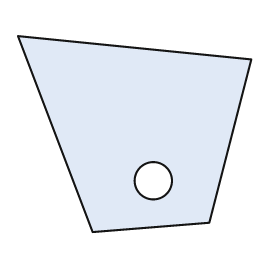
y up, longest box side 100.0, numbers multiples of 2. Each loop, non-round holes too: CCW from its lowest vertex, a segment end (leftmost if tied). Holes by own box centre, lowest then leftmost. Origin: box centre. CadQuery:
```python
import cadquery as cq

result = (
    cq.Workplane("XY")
    .moveTo(-18.0, -42.0)
    .lineTo(32.0, -38.0)
    .lineTo(50.0, 32.0)
    .lineTo(-50.0, 42.0)
    .close()
    .moveTo(8.0, -20.0)
    .circle(8.0)
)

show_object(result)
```